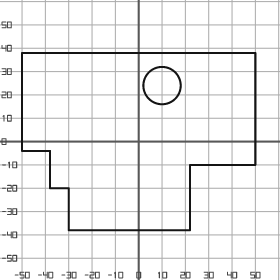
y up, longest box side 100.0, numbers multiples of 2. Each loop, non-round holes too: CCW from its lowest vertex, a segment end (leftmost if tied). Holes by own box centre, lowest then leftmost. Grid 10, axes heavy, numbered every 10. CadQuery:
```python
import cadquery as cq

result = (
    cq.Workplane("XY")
    .moveTo(-30.0, -38.0)
    .lineTo(22.0, -38.0)
    .lineTo(22.0, -10.0)
    .lineTo(50.0, -10.0)
    .lineTo(50.0, 38.0)
    .lineTo(-50.0, 38.0)
    .lineTo(-50.0, -4.0)
    .lineTo(-38.0, -4.0)
    .lineTo(-38.0, -20.0)
    .lineTo(-30.0, -20.0)
    .close()
    .moveTo(10.0, 24.0)
    .circle(8.0)
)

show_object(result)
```